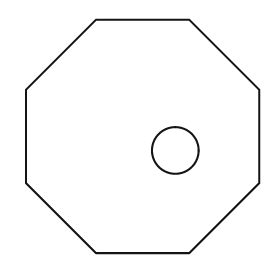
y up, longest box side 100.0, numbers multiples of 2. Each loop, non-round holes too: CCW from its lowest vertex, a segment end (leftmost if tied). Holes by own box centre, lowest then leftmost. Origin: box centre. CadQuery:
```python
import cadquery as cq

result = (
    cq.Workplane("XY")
    .moveTo(-20.0, -50.0)
    .lineTo(20.0, -50.0)
    .lineTo(50.0, -20.0)
    .lineTo(50.0, 20.0)
    .lineTo(20.0, 50.0)
    .lineTo(-20.0, 50.0)
    .lineTo(-50.0, 20.0)
    .lineTo(-50.0, -20.0)
    .close()
    .moveTo(14.0, -6.0)
    .circle(10.0)
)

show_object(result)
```